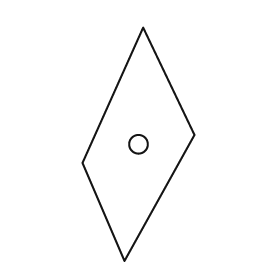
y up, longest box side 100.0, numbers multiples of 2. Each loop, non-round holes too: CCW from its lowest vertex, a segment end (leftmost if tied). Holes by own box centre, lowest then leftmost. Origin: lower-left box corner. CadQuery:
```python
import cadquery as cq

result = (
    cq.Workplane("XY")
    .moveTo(18.0, 0.0)
    .lineTo(48.0, 54.0)
    .lineTo(26.0, 100.0)
    .lineTo(0.0, 42.0)
    .close()
    .moveTo(24.0, 50.0)
    .circle(4.0)
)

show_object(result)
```